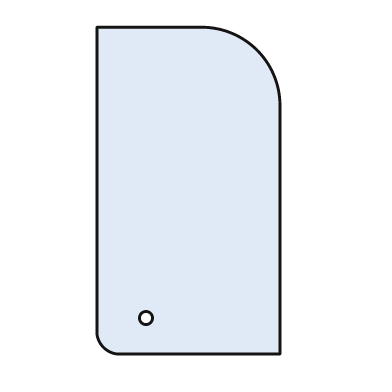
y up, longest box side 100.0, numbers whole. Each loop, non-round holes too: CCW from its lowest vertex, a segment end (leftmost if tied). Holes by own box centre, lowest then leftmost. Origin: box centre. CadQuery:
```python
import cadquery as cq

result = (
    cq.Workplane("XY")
    .moveTo(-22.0, -50.0)
    .lineTo(28.0, -50.0)
    .lineTo(28.0, 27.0)
    .threePointArc((21.0, 43.0), (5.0, 50.0))
    .lineTo(-28.0, 50.0)
    .lineTo(-28.0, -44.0)
    .threePointArc((-26.0, -48.0), (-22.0, -50.0))
    .close()
    .moveTo(-13.0, -39.0)
    .circle(2.0)
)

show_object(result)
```